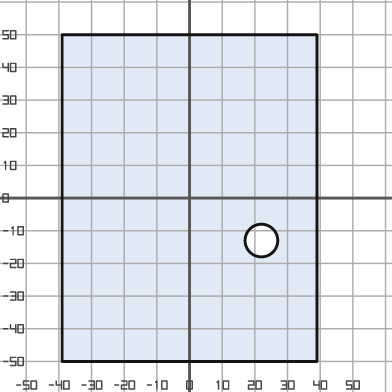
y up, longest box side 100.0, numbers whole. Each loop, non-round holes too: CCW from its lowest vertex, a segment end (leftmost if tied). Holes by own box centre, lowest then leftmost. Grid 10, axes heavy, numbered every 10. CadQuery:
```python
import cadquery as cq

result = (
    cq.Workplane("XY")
    .moveTo(-39.0, -50.0)
    .lineTo(39.0, -50.0)
    .lineTo(39.0, 50.0)
    .lineTo(-39.0, 50.0)
    .close()
    .moveTo(22.0, -13.0)
    .circle(5.0)
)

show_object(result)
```